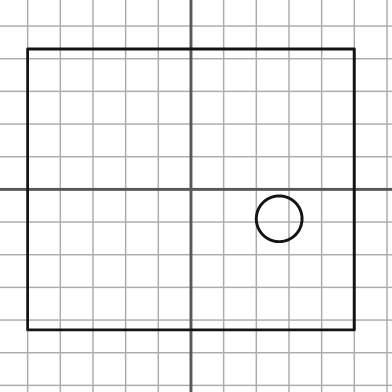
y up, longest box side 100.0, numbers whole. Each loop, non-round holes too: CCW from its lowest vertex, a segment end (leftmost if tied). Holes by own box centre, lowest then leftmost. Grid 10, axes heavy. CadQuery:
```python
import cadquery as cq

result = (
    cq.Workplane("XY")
    .moveTo(-50.0, -43.0)
    .lineTo(50.0, -43.0)
    .lineTo(50.0, 43.0)
    .lineTo(-50.0, 43.0)
    .close()
    .moveTo(27.0, -9.0)
    .circle(7.0)
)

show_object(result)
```